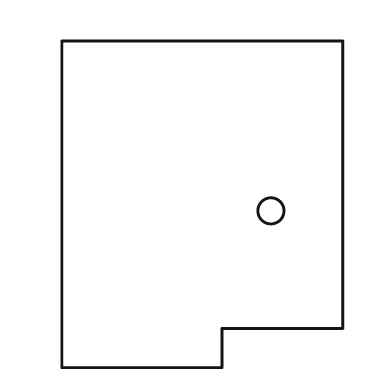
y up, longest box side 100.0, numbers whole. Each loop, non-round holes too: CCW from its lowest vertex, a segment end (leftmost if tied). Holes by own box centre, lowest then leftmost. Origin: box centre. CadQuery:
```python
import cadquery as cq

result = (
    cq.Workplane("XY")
    .moveTo(-43.0, -50.0)
    .lineTo(6.0, -50.0)
    .lineTo(6.0, -38.0)
    .lineTo(43.0, -38.0)
    .lineTo(43.0, 50.0)
    .lineTo(-43.0, 50.0)
    .close()
    .moveTo(21.0, -2.0)
    .circle(4.0)
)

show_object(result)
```